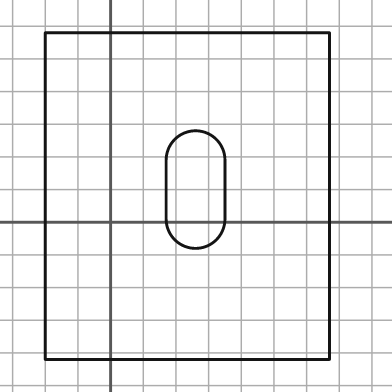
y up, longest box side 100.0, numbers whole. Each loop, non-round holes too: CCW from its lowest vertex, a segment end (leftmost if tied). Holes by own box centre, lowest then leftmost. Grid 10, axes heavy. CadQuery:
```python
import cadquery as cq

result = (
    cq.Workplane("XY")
    .moveTo(-20.0, -42.0)
    .lineTo(67.0, -42.0)
    .lineTo(67.0, 58.0)
    .lineTo(-20.0, 58.0)
    .close()
    .moveTo(17.0, 1.0)
    .threePointArc((26.0, -8.0), (35.0, 1.0))
    .lineTo(35.0, 19.0)
    .threePointArc((26.0, 28.0), (17.0, 19.0))
    .close()
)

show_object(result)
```